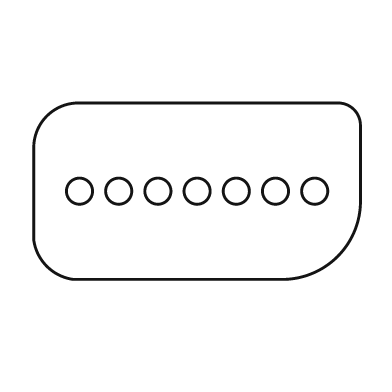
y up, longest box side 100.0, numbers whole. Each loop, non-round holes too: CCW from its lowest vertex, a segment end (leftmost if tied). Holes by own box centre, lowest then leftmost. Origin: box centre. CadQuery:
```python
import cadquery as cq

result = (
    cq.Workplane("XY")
    .moveTo(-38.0, -27.0)
    .lineTo(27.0, -27.0)
    .threePointArc((43.0, -20.0), (50.0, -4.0))
    .lineTo(50.0, 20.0)
    .threePointArc((48.0, 25.0), (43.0, 27.0))
    .lineTo(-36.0, 27.0)
    .threePointArc((-46.0, 23.0), (-50.0, 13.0))
    .lineTo(-50.0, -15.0)
    .threePointArc((-46.0, -23.0), (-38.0, -27.0))
    .close()
    .moveTo(-36.0, 0.0)
    .circle(4.0)
    .moveTo(-24.0, 0.0)
    .circle(4.0)
    .moveTo(-12.0, 0.0)
    .circle(4.0)
    .moveTo(0.0, 0.0)
    .circle(4.0)
    .moveTo(12.0, 0.0)
    .circle(4.0)
    .moveTo(24.0, 0.0)
    .circle(4.0)
    .moveTo(36.0, 0.0)
    .circle(4.0)
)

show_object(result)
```